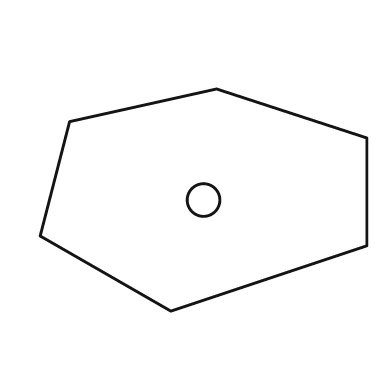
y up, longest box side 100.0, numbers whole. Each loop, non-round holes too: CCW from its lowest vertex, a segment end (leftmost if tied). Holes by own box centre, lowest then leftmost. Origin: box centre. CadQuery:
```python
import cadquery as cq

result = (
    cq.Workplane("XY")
    .moveTo(-10.0, -34.0)
    .lineTo(50.0, -14.0)
    .lineTo(50.0, 19.0)
    .lineTo(4.0, 34.0)
    .lineTo(-41.0, 24.0)
    .lineTo(-50.0, -11.0)
    .close()
    .moveTo(0.0, 0.0)
    .circle(5.0)
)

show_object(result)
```